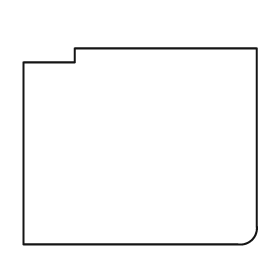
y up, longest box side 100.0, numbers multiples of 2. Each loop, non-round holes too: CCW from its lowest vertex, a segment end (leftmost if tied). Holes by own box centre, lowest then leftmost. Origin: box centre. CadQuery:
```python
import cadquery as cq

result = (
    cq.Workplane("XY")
    .moveTo(-50.0, -42.0)
    .lineTo(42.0, -42.0)
    .threePointArc((48.0, -40.0), (50.0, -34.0))
    .lineTo(50.0, 42.0)
    .lineTo(-28.0, 42.0)
    .lineTo(-28.0, 36.0)
    .lineTo(-50.0, 36.0)
    .close()
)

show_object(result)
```